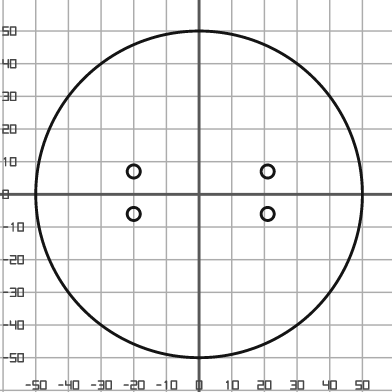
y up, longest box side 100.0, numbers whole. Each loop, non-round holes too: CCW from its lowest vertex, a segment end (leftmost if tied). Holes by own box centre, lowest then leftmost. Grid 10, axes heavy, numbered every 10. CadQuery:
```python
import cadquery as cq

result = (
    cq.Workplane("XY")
    .moveTo(0.0, 0.0)
    .circle(50.0)
    .moveTo(-20.0, -6.0)
    .circle(2.0)
    .moveTo(21.0, -6.0)
    .circle(2.0)
    .moveTo(-20.0, 7.0)
    .circle(2.0)
    .moveTo(21.0, 7.0)
    .circle(2.0)
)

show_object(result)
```